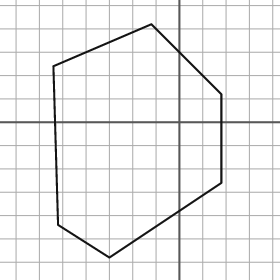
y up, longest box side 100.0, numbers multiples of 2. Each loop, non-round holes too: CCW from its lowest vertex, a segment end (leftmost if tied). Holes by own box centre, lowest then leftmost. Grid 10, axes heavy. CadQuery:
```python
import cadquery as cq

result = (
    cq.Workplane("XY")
    .moveTo(-30.0, -58.0)
    .lineTo(18.0, -26.0)
    .lineTo(18.0, 12.0)
    .lineTo(-12.0, 42.0)
    .lineTo(-54.0, 24.0)
    .lineTo(-52.0, -44.0)
    .close()
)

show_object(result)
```